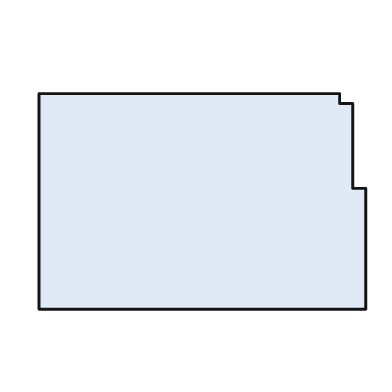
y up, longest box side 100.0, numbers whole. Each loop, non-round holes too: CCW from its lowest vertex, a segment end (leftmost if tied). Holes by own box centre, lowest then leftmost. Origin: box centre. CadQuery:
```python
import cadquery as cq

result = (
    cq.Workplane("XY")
    .moveTo(-50.0, -33.0)
    .lineTo(50.0, -33.0)
    .lineTo(50.0, 4.0)
    .lineTo(46.0, 4.0)
    .lineTo(46.0, 30.0)
    .lineTo(42.0, 30.0)
    .lineTo(42.0, 33.0)
    .lineTo(-50.0, 33.0)
    .close()
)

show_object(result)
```